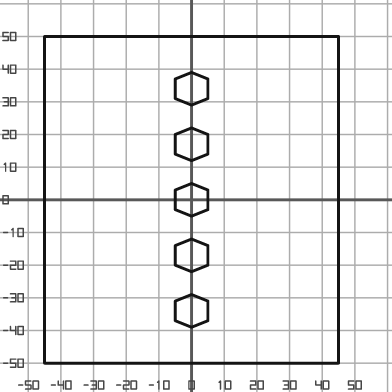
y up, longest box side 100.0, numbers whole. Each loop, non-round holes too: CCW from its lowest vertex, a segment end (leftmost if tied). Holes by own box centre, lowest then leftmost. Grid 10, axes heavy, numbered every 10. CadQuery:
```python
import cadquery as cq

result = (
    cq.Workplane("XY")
    .moveTo(-45.0, -50.0)
    .lineTo(45.0, -50.0)
    .lineTo(45.0, 50.0)
    .lineTo(-45.0, 50.0)
    .close()
    .moveTo(0.0, -39.0)
    .lineTo(5.0, -37.0)
    .lineTo(5.0, -31.0)
    .lineTo(0.0, -29.0)
    .lineTo(-5.0, -31.0)
    .lineTo(-5.0, -37.0)
    .close()
    .moveTo(0.0, -22.0)
    .lineTo(5.0, -20.0)
    .lineTo(5.0, -14.0)
    .lineTo(0.0, -12.0)
    .lineTo(-5.0, -14.0)
    .lineTo(-5.0, -20.0)
    .close()
    .moveTo(0.0, -5.0)
    .lineTo(5.0, -3.0)
    .lineTo(5.0, 3.0)
    .lineTo(0.0, 5.0)
    .lineTo(-5.0, 3.0)
    .lineTo(-5.0, -3.0)
    .close()
    .moveTo(0.0, 12.0)
    .lineTo(5.0, 14.0)
    .lineTo(5.0, 20.0)
    .lineTo(0.0, 22.0)
    .lineTo(-5.0, 20.0)
    .lineTo(-5.0, 14.0)
    .close()
    .moveTo(0.0, 29.0)
    .lineTo(5.0, 31.0)
    .lineTo(5.0, 37.0)
    .lineTo(0.0, 39.0)
    .lineTo(-5.0, 37.0)
    .lineTo(-5.0, 31.0)
    .close()
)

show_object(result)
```